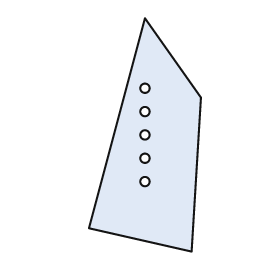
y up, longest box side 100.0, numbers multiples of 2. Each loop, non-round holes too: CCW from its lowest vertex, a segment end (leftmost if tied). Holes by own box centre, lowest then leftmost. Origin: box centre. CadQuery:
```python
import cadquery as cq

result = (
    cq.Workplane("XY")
    .moveTo(20.0, -50.0)
    .lineTo(24.0, 16.0)
    .lineTo(0.0, 50.0)
    .lineTo(-24.0, -40.0)
    .close()
    .moveTo(0.0, -20.0)
    .circle(2.0)
    .moveTo(0.0, -10.0)
    .circle(2.0)
    .moveTo(0.0, 0.0)
    .circle(2.0)
    .moveTo(0.0, 10.0)
    .circle(2.0)
    .moveTo(0.0, 20.0)
    .circle(2.0)
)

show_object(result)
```